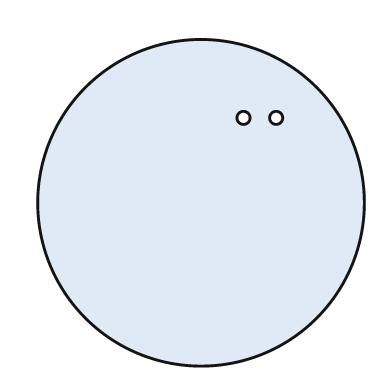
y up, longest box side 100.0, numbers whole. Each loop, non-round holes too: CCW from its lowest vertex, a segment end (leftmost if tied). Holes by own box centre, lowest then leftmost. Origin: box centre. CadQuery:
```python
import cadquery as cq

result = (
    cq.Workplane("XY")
    .moveTo(0.0, 0.0)
    .circle(50.0)
    .moveTo(13.0, 26.0)
    .circle(2.0)
    .moveTo(23.0, 26.0)
    .circle(2.0)
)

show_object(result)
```